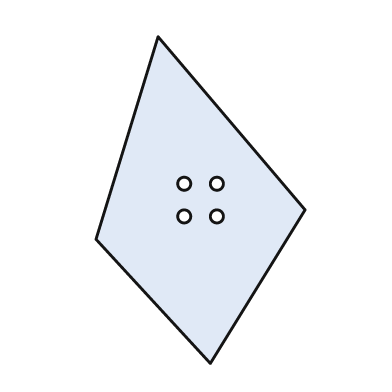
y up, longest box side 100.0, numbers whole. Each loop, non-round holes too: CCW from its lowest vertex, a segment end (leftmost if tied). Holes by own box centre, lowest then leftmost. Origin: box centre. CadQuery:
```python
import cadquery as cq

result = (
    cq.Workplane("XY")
    .moveTo(3.0, -50.0)
    .lineTo(32.0, -3.0)
    .lineTo(-13.0, 50.0)
    .lineTo(-32.0, -12.0)
    .close()
    .moveTo(-5.0, -5.0)
    .circle(2.0)
    .moveTo(5.0, -5.0)
    .circle(2.0)
    .moveTo(-5.0, 5.0)
    .circle(2.0)
    .moveTo(5.0, 5.0)
    .circle(2.0)
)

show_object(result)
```